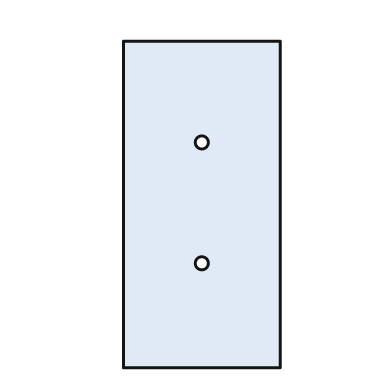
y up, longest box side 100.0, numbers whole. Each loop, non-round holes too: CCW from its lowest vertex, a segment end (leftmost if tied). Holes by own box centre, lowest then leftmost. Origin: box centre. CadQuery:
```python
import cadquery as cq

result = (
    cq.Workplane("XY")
    .moveTo(-24.0, -50.0)
    .lineTo(24.0, -50.0)
    .lineTo(24.0, 50.0)
    .lineTo(-24.0, 50.0)
    .close()
    .moveTo(0.0, -18.0)
    .circle(2.0)
    .moveTo(0.0, 19.0)
    .circle(2.0)
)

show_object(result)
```